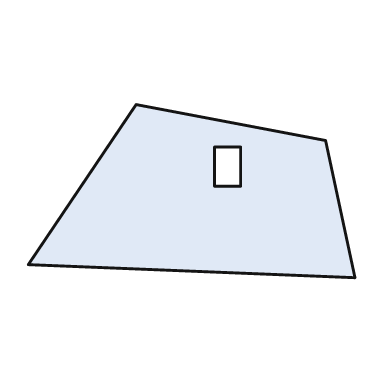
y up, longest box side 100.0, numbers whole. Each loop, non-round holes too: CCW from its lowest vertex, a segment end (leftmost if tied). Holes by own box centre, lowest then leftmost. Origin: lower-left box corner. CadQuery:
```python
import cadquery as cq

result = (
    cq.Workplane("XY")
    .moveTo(100.0, 0.0)
    .lineTo(91.0, 42.0)
    .lineTo(33.0, 53.0)
    .lineTo(0.0, 4.0)
    .close()
    .moveTo(57.0, 28.0)
    .lineTo(65.0, 28.0)
    .lineTo(65.0, 40.0)
    .lineTo(57.0, 40.0)
    .close()
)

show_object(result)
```